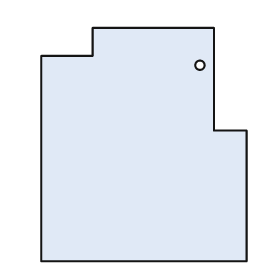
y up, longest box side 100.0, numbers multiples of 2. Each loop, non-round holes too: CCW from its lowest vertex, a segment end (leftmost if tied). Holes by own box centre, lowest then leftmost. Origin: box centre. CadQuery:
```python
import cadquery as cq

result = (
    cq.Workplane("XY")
    .moveTo(-44.0, -50.0)
    .lineTo(44.0, -50.0)
    .lineTo(44.0, 6.0)
    .lineTo(30.0, 6.0)
    .lineTo(30.0, 50.0)
    .lineTo(-22.0, 50.0)
    .lineTo(-22.0, 38.0)
    .lineTo(-44.0, 38.0)
    .close()
    .moveTo(24.0, 34.0)
    .circle(2.0)
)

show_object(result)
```